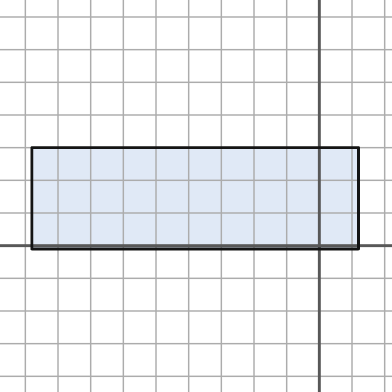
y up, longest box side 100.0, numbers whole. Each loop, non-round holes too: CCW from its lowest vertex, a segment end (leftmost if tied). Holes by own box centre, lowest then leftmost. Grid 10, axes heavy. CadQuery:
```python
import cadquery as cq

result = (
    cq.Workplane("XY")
    .moveTo(-88.0, -1.0)
    .lineTo(12.0, -1.0)
    .lineTo(12.0, 30.0)
    .lineTo(-88.0, 30.0)
    .close()
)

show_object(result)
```